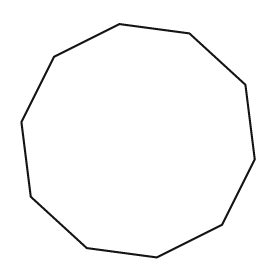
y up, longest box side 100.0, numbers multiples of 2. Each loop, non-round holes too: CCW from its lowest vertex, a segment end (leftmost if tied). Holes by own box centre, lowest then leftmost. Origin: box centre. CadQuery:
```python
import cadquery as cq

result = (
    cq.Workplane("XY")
    .moveTo(8.0, -50.0)
    .lineTo(36.0, -36.0)
    .lineTo(50.0, -8.0)
    .lineTo(46.0, 24.0)
    .lineTo(22.0, 46.0)
    .lineTo(-8.0, 50.0)
    .lineTo(-36.0, 36.0)
    .lineTo(-50.0, 8.0)
    .lineTo(-46.0, -24.0)
    .lineTo(-22.0, -46.0)
    .close()
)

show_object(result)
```